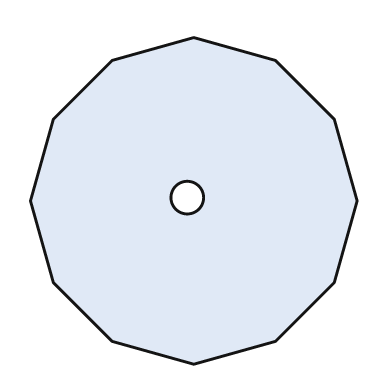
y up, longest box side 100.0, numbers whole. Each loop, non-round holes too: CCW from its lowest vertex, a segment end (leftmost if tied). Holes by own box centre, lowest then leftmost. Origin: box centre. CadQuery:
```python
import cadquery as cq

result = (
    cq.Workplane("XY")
    .moveTo(0.0, -50.0)
    .lineTo(25.0, -43.0)
    .lineTo(43.0, -25.0)
    .lineTo(50.0, 0.0)
    .lineTo(43.0, 25.0)
    .lineTo(25.0, 43.0)
    .lineTo(0.0, 50.0)
    .lineTo(-25.0, 43.0)
    .lineTo(-43.0, 25.0)
    .lineTo(-50.0, 0.0)
    .lineTo(-43.0, -25.0)
    .lineTo(-25.0, -43.0)
    .close()
    .moveTo(-2.0, 1.0)
    .circle(5.0)
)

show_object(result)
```